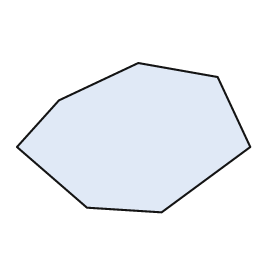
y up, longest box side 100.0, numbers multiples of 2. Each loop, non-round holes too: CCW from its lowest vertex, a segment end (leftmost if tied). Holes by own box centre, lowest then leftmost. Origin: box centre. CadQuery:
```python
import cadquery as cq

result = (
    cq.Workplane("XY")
    .moveTo(12.0, -32.0)
    .lineTo(50.0, -4.0)
    .lineTo(36.0, 26.0)
    .lineTo(2.0, 32.0)
    .lineTo(-32.0, 16.0)
    .lineTo(-50.0, -4.0)
    .lineTo(-20.0, -30.0)
    .close()
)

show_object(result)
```